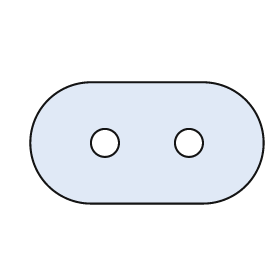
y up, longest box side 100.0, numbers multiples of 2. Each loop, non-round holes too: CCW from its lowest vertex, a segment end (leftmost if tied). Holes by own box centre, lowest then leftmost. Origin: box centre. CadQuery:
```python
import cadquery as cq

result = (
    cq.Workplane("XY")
    .moveTo(-24.0, -26.0)
    .lineTo(24.0, -26.0)
    .threePointArc((50.0, 0.0), (24.0, 26.0))
    .lineTo(-24.0, 26.0)
    .threePointArc((-50.0, 0.0), (-24.0, -26.0))
    .close()
    .moveTo(-18.0, 0.0)
    .circle(6.0)
    .moveTo(18.0, 0.0)
    .circle(6.0)
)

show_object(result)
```